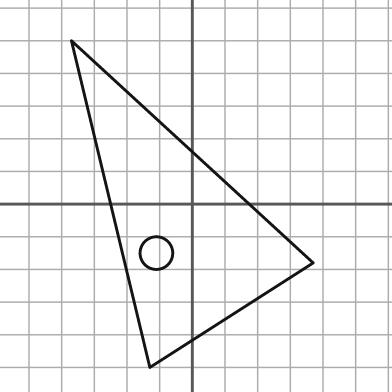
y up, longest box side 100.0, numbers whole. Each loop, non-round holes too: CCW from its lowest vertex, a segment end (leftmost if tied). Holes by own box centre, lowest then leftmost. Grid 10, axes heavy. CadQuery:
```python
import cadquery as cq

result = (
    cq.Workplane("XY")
    .moveTo(-13.0, -50.0)
    .lineTo(37.0, -18.0)
    .lineTo(-37.0, 50.0)
    .close()
    .moveTo(-11.0, -15.0)
    .circle(5.0)
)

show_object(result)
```